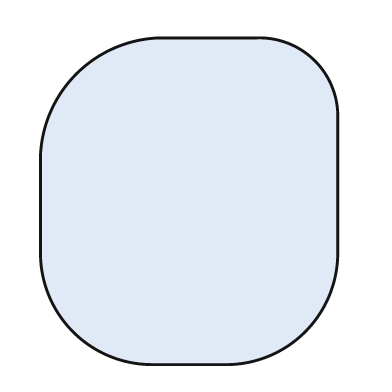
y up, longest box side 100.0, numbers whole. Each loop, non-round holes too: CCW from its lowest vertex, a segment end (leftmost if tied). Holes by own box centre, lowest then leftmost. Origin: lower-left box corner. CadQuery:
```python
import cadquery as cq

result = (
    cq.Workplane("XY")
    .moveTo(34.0, 0.0)
    .lineTo(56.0, 0.0)
    .threePointArc((81.0, 10.0), (91.0, 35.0))
    .lineTo(91.0, 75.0)
    .threePointArc((84.0, 93.0), (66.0, 100.0))
    .lineTo(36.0, 100.0)
    .threePointArc((11.0, 89.0), (0.0, 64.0))
    .lineTo(0.0, 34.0)
    .threePointArc((10.0, 10.0), (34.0, 0.0))
    .close()
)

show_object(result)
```